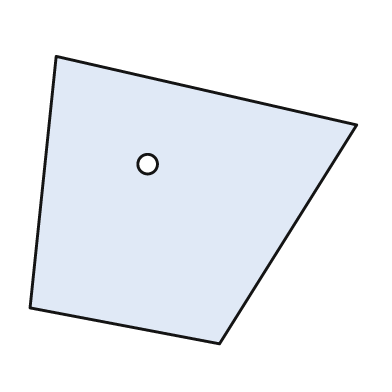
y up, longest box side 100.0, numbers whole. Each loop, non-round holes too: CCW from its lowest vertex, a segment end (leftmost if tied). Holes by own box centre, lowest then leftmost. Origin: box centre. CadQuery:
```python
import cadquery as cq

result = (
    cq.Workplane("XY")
    .moveTo(8.0, -44.0)
    .lineTo(50.0, 23.0)
    .lineTo(-42.0, 44.0)
    .lineTo(-50.0, -33.0)
    .close()
    .moveTo(-14.0, 11.0)
    .circle(3.0)
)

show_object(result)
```